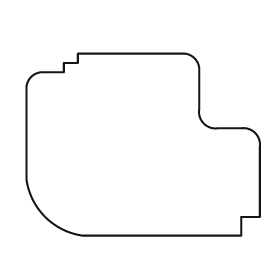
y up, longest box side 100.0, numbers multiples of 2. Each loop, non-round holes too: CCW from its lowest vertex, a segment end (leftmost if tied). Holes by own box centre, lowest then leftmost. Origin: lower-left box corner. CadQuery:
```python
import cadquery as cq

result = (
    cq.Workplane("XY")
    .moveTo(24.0, 0.0)
    .lineTo(92.0, 0.0)
    .lineTo(92.0, 8.0)
    .lineTo(100.0, 8.0)
    .lineTo(100.0, 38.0)
    .threePointArc((98.0, 44.0), (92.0, 46.0))
    .lineTo(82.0, 46.0)
    .threePointArc((76.0, 48.0), (74.0, 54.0))
    .lineTo(74.0, 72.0)
    .threePointArc((72.0, 76.0), (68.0, 78.0))
    .lineTo(22.0, 78.0)
    .lineTo(22.0, 74.0)
    .lineTo(16.0, 74.0)
    .lineTo(16.0, 70.0)
    .lineTo(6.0, 70.0)
    .threePointArc((2.0, 68.0), (0.0, 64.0))
    .lineTo(0.0, 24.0)
    .threePointArc((8.0, 8.0), (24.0, 0.0))
    .close()
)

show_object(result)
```